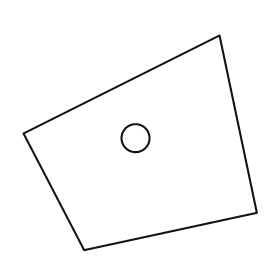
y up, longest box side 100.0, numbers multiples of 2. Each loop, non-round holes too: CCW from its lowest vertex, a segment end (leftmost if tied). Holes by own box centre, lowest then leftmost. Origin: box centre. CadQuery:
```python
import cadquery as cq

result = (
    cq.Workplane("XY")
    .moveTo(-24.0, -46.0)
    .lineTo(50.0, -30.0)
    .lineTo(34.0, 46.0)
    .lineTo(-50.0, 4.0)
    .close()
    .moveTo(-2.0, 2.0)
    .circle(6.0)
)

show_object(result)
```